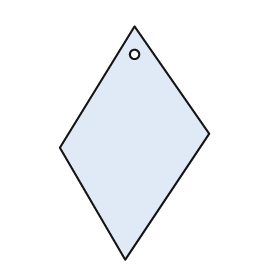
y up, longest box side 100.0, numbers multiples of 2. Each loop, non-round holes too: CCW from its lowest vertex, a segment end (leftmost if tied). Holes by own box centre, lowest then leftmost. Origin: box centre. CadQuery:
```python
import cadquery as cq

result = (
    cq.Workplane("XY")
    .moveTo(-4.0, -50.0)
    .lineTo(32.0, 4.0)
    .lineTo(0.0, 50.0)
    .lineTo(-32.0, -2.0)
    .close()
    .moveTo(0.0, 38.0)
    .circle(2.0)
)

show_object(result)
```